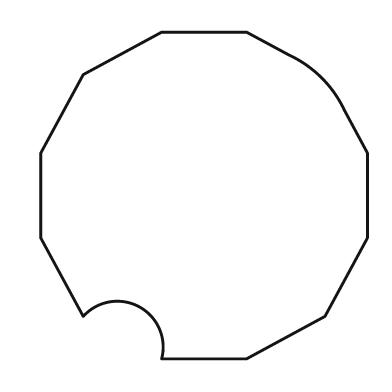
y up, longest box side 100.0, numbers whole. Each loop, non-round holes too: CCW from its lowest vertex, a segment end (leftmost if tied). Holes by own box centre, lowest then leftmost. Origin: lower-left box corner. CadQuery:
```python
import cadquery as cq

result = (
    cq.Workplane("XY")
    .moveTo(37.0, 0.0)
    .lineTo(63.0, 0.0)
    .lineTo(87.0, 13.0)
    .lineTo(100.0, 37.0)
    .lineTo(100.0, 63.0)
    .lineTo(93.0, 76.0)
    .threePointArc((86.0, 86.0), (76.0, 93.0))
    .lineTo(63.0, 100.0)
    .lineTo(37.0, 100.0)
    .lineTo(13.0, 87.0)
    .lineTo(0.0, 63.0)
    .lineTo(0.0, 37.0)
    .lineTo(13.0, 13.0)
    .threePointArc((30.0, 16.0), (37.0, 0.0))
    .close()
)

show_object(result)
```